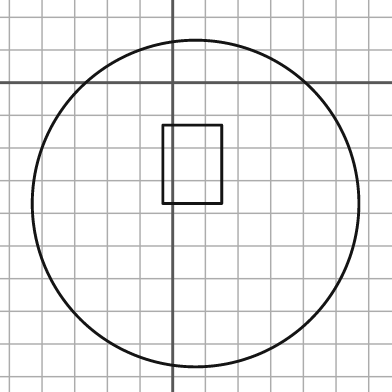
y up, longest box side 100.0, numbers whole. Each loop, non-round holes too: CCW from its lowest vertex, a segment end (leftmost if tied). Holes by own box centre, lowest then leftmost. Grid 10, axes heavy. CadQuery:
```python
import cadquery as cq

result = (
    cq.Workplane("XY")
    .moveTo(7.0, -37.0)
    .circle(50.0)
    .moveTo(-3.0, -37.0)
    .lineTo(15.0, -37.0)
    .lineTo(15.0, -13.0)
    .lineTo(-3.0, -13.0)
    .close()
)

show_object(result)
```